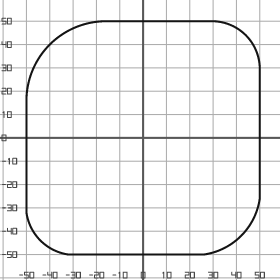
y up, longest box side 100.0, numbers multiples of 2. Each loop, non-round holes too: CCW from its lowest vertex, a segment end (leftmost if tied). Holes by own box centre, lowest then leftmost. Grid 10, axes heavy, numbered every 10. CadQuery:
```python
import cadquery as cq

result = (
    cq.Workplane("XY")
    .moveTo(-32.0, -50.0)
    .lineTo(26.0, -50.0)
    .threePointArc((42.0, -42.0), (50.0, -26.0))
    .lineTo(50.0, 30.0)
    .threePointArc((44.0, 44.0), (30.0, 50.0))
    .lineTo(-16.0, 50.0)
    .threePointArc((-40.0, 40.0), (-50.0, 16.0))
    .lineTo(-50.0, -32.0)
    .threePointArc((-44.0, -44.0), (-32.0, -50.0))
    .close()
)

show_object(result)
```